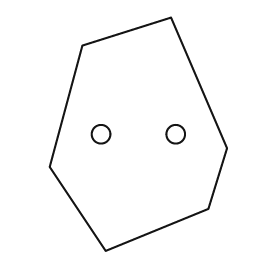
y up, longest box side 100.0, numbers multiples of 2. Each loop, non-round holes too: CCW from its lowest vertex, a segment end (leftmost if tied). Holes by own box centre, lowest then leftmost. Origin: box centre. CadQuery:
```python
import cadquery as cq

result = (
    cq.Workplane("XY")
    .moveTo(-14.0, -50.0)
    .lineTo(30.0, -32.0)
    .lineTo(38.0, -6.0)
    .lineTo(14.0, 50.0)
    .lineTo(-24.0, 38.0)
    .lineTo(-38.0, -14.0)
    .close()
    .moveTo(-16.0, 0.0)
    .circle(4.0)
    .moveTo(16.0, 0.0)
    .circle(4.0)
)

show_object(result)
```